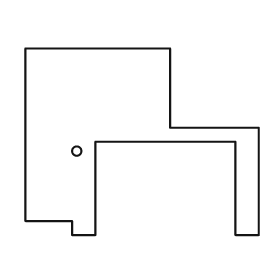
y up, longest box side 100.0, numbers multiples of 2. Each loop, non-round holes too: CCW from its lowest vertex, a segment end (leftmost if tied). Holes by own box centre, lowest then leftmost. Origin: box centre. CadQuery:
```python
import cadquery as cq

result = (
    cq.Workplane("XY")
    .moveTo(-30.0, -40.0)
    .lineTo(-20.0, -40.0)
    .lineTo(-20.0, 0.0)
    .lineTo(40.0, 0.0)
    .lineTo(40.0, -40.0)
    .lineTo(50.0, -40.0)
    .lineTo(50.0, 6.0)
    .lineTo(12.0, 6.0)
    .lineTo(12.0, 40.0)
    .lineTo(-50.0, 40.0)
    .lineTo(-50.0, -34.0)
    .lineTo(-30.0, -34.0)
    .close()
    .moveTo(-28.0, -4.0)
    .circle(2.0)
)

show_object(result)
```